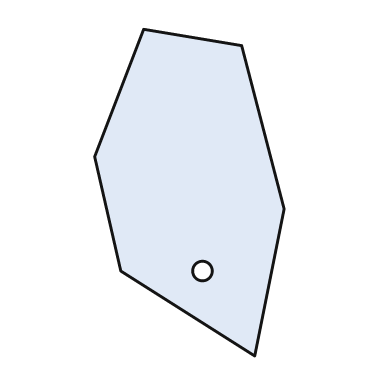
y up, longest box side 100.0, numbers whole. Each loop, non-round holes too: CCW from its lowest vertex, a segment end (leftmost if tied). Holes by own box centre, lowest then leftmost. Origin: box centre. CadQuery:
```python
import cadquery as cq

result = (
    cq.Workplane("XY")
    .moveTo(20.0, -50.0)
    .lineTo(29.0, -5.0)
    .lineTo(16.0, 45.0)
    .lineTo(-14.0, 50.0)
    .lineTo(-29.0, 11.0)
    .lineTo(-21.0, -24.0)
    .close()
    .moveTo(4.0, -24.0)
    .circle(3.0)
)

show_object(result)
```